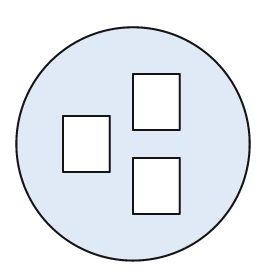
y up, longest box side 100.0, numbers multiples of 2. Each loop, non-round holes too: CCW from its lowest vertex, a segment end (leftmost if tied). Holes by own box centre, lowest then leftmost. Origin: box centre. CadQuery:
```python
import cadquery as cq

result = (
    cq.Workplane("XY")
    .moveTo(0.0, 0.0)
    .circle(50.0)
    .moveTo(0.0, -30.0)
    .lineTo(20.0, -30.0)
    .lineTo(20.0, -6.0)
    .lineTo(0.0, -6.0)
    .close()
    .moveTo(-30.0, -12.0)
    .lineTo(-10.0, -12.0)
    .lineTo(-10.0, 12.0)
    .lineTo(-30.0, 12.0)
    .close()
    .moveTo(0.0, 6.0)
    .lineTo(20.0, 6.0)
    .lineTo(20.0, 30.0)
    .lineTo(0.0, 30.0)
    .close()
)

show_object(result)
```